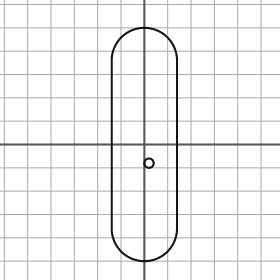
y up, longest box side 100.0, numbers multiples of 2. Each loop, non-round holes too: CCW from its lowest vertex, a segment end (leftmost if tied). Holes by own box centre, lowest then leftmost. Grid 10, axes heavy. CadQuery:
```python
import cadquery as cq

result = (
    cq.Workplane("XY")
    .moveTo(-14.0, -36.0)
    .threePointArc((0.0, -50.0), (14.0, -36.0))
    .lineTo(14.0, 36.0)
    .threePointArc((0.0, 50.0), (-14.0, 36.0))
    .close()
    .moveTo(2.0, -8.0)
    .circle(2.0)
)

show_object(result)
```